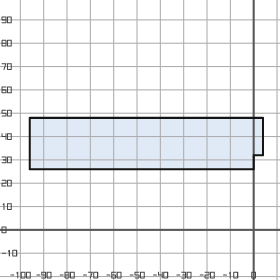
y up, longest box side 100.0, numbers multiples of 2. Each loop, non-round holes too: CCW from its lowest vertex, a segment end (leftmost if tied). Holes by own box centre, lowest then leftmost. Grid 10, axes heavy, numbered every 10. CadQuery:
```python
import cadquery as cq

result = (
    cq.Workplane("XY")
    .moveTo(-96.0, 26.0)
    .lineTo(0.0, 26.0)
    .lineTo(0.0, 32.0)
    .lineTo(4.0, 32.0)
    .lineTo(4.0, 48.0)
    .lineTo(-96.0, 48.0)
    .close()
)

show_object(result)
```